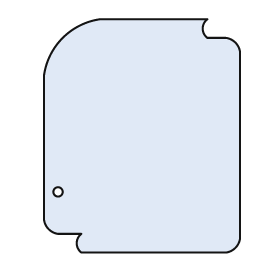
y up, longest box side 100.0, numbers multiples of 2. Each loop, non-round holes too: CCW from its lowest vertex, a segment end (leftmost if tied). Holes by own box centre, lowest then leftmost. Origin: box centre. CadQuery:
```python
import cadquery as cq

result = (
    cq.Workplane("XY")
    .moveTo(-26.0, -50.0)
    .lineTo(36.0, -50.0)
    .threePointArc((40.0, -48.0), (42.0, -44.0))
    .lineTo(42.0, 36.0)
    .threePointArc((40.0, 40.0), (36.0, 42.0))
    .lineTo(28.0, 42.0)
    .threePointArc((26.0, 46.0), (28.0, 50.0))
    .lineTo(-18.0, 50.0)
    .threePointArc((-34.0, 42.0), (-42.0, 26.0))
    .lineTo(-42.0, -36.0)
    .threePointArc((-40.0, -40.0), (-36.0, -42.0))
    .lineTo(-26.0, -42.0)
    .threePointArc((-28.0, -46.0), (-26.0, -50.0))
    .close()
    .moveTo(-36.0, -24.0)
    .circle(2.0)
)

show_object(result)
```